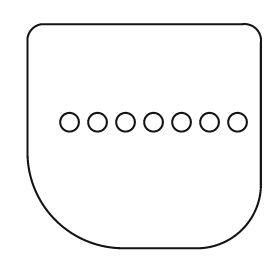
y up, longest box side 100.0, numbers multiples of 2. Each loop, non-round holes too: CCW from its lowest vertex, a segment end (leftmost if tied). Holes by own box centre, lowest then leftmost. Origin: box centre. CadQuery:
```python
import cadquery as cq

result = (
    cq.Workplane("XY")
    .moveTo(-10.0, -48.0)
    .lineTo(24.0, -48.0)
    .threePointArc((42.0, -40.0), (50.0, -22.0))
    .lineTo(50.0, 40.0)
    .threePointArc((48.0, 46.0), (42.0, 48.0))
    .lineTo(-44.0, 48.0)
    .threePointArc((-48.0, 46.0), (-50.0, 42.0))
    .lineTo(-50.0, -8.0)
    .threePointArc((-38.0, -36.0), (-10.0, -48.0))
    .close()
    .moveTo(-32.0, 6.0)
    .circle(4.0)
    .moveTo(-20.0, 6.0)
    .circle(4.0)
    .moveTo(-8.0, 6.0)
    .circle(4.0)
    .moveTo(4.0, 6.0)
    .circle(4.0)
    .moveTo(16.0, 6.0)
    .circle(4.0)
    .moveTo(28.0, 6.0)
    .circle(4.0)
    .moveTo(40.0, 6.0)
    .circle(4.0)
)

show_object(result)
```